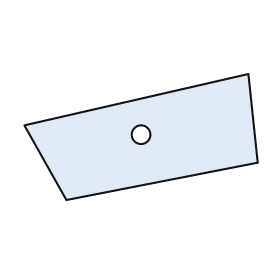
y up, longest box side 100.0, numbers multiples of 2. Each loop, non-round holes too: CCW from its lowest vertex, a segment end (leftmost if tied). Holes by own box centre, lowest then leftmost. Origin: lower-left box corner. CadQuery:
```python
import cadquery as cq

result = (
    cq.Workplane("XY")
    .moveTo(18.0, 0.0)
    .lineTo(100.0, 16.0)
    .lineTo(96.0, 54.0)
    .lineTo(0.0, 32.0)
    .close()
    .moveTo(50.0, 28.0)
    .circle(4.0)
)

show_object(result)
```